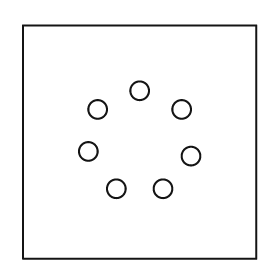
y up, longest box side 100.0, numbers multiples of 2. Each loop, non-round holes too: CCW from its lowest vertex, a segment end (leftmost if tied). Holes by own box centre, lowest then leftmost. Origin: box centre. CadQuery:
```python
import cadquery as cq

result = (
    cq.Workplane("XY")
    .moveTo(-50.0, -50.0)
    .lineTo(50.0, -50.0)
    .lineTo(50.0, 50.0)
    .lineTo(-50.0, 50.0)
    .close()
    .moveTo(-10.0, -20.0)
    .circle(4.0)
    .moveTo(10.0, -20.0)
    .circle(4.0)
    .moveTo(22.0, -6.0)
    .circle(4.0)
    .moveTo(-22.0, -4.0)
    .circle(4.0)
    .moveTo(-18.0, 14.0)
    .circle(4.0)
    .moveTo(18.0, 14.0)
    .circle(4.0)
    .moveTo(0.0, 22.0)
    .circle(4.0)
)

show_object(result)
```